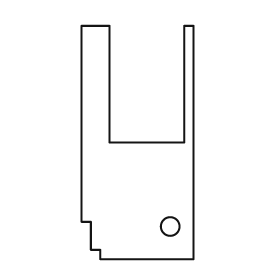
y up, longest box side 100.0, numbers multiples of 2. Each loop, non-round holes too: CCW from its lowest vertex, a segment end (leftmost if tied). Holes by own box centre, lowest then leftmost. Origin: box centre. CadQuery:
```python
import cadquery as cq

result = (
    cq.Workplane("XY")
    .moveTo(-16.0, -50.0)
    .lineTo(24.0, -50.0)
    .lineTo(24.0, 50.0)
    .lineTo(20.0, 50.0)
    .lineTo(20.0, 0.0)
    .lineTo(-12.0, 0.0)
    .lineTo(-12.0, 50.0)
    .lineTo(-24.0, 50.0)
    .lineTo(-24.0, -34.0)
    .lineTo(-20.0, -34.0)
    .lineTo(-20.0, -46.0)
    .lineTo(-16.0, -46.0)
    .close()
    .moveTo(14.0, -36.0)
    .circle(4.0)
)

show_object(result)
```